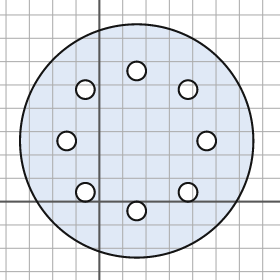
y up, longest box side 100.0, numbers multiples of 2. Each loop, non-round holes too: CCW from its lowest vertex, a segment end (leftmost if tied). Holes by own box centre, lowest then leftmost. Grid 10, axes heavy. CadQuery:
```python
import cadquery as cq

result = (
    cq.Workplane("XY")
    .moveTo(16.0, 26.0)
    .circle(50.0)
    .moveTo(16.0, -4.0)
    .circle(4.0)
    .moveTo(-6.0, 4.0)
    .circle(4.0)
    .moveTo(38.0, 4.0)
    .circle(4.0)
    .moveTo(-14.0, 26.0)
    .circle(4.0)
    .moveTo(46.0, 26.0)
    .circle(4.0)
    .moveTo(-6.0, 48.0)
    .circle(4.0)
    .moveTo(38.0, 48.0)
    .circle(4.0)
    .moveTo(16.0, 56.0)
    .circle(4.0)
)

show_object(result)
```